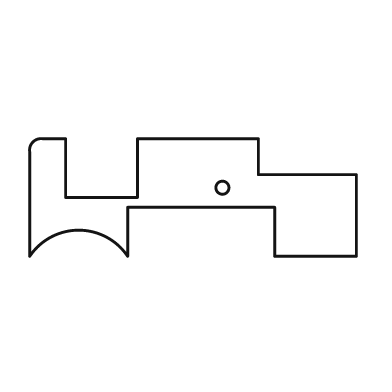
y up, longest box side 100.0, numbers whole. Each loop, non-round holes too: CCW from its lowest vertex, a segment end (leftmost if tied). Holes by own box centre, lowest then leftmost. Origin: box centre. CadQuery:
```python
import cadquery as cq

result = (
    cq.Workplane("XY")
    .moveTo(-50.0, -18.0)
    .threePointArc((-35.0, -10.0), (-20.0, -18.0))
    .lineTo(-20.0, -3.0)
    .lineTo(25.0, -3.0)
    .lineTo(25.0, -18.0)
    .lineTo(50.0, -18.0)
    .lineTo(50.0, 7.0)
    .lineTo(20.0, 7.0)
    .lineTo(20.0, 18.0)
    .lineTo(-17.0, 18.0)
    .lineTo(-17.0, 0.0)
    .lineTo(-39.0, 0.0)
    .lineTo(-39.0, 18.0)
    .lineTo(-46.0, 18.0)
    .threePointArc((-49.0, 17.0), (-50.0, 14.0))
    .close()
    .moveTo(9.0, 3.0)
    .circle(2.0)
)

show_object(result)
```